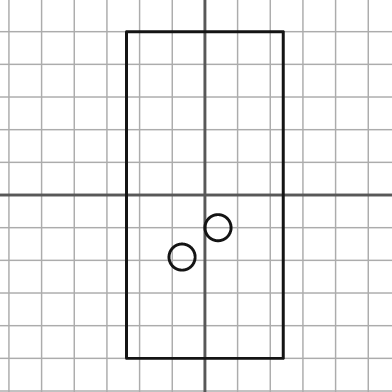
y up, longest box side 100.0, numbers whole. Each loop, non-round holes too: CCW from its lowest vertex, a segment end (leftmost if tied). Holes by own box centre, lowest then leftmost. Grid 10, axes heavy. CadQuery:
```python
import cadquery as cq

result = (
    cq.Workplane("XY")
    .moveTo(-24.0, -50.0)
    .lineTo(24.0, -50.0)
    .lineTo(24.0, 50.0)
    .lineTo(-24.0, 50.0)
    .close()
    .moveTo(-7.0, -19.0)
    .circle(4.0)
    .moveTo(4.0, -10.0)
    .circle(4.0)
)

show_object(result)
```